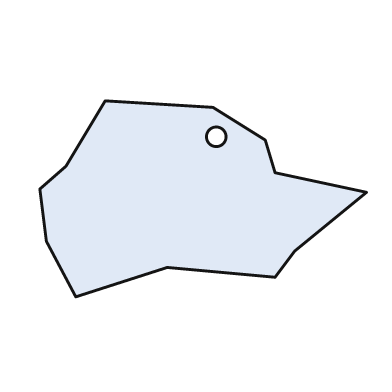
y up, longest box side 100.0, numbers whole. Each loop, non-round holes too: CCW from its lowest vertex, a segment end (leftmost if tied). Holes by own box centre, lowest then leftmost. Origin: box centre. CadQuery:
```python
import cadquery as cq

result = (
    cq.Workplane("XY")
    .moveTo(-39.0, -30.0)
    .lineTo(-11.0, -21.0)
    .lineTo(22.0, -24.0)
    .lineTo(28.0, -16.0)
    .lineTo(50.0, 2.0)
    .lineTo(22.0, 8.0)
    .lineTo(19.0, 18.0)
    .lineTo(3.0, 28.0)
    .lineTo(-30.0, 30.0)
    .lineTo(-42.0, 10.0)
    .lineTo(-50.0, 3.0)
    .lineTo(-48.0, -13.0)
    .close()
    .moveTo(4.0, 19.0)
    .circle(3.0)
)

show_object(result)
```